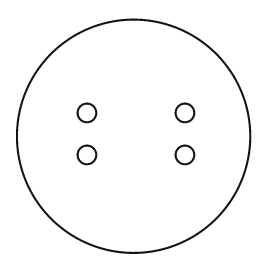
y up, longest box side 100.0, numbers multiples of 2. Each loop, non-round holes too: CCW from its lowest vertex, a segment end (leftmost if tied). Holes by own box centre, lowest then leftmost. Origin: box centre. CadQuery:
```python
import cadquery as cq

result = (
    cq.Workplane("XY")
    .moveTo(0.0, 0.0)
    .circle(50.0)
    .moveTo(-20.0, -8.0)
    .circle(4.0)
    .moveTo(22.0, -8.0)
    .circle(4.0)
    .moveTo(-20.0, 10.0)
    .circle(4.0)
    .moveTo(22.0, 10.0)
    .circle(4.0)
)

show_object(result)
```